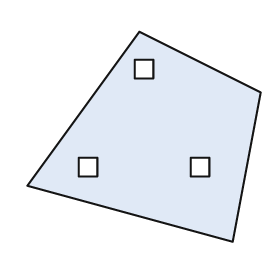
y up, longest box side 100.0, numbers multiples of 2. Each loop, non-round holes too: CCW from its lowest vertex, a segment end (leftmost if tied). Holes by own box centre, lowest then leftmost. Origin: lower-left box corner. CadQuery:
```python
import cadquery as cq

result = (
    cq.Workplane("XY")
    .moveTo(88.0, 0.0)
    .lineTo(100.0, 64.0)
    .lineTo(48.0, 90.0)
    .lineTo(0.0, 24.0)
    .close()
    .moveTo(22.0, 28.0)
    .lineTo(30.0, 28.0)
    .lineTo(30.0, 36.0)
    .lineTo(22.0, 36.0)
    .close()
    .moveTo(70.0, 28.0)
    .lineTo(78.0, 28.0)
    .lineTo(78.0, 36.0)
    .lineTo(70.0, 36.0)
    .close()
    .moveTo(46.0, 70.0)
    .lineTo(54.0, 70.0)
    .lineTo(54.0, 78.0)
    .lineTo(46.0, 78.0)
    .close()
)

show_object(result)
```